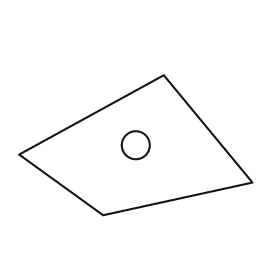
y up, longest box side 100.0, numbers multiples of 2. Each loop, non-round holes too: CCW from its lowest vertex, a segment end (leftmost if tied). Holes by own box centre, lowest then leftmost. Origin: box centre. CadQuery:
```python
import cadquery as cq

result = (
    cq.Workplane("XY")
    .moveTo(-14.0, -30.0)
    .lineTo(50.0, -16.0)
    .lineTo(12.0, 30.0)
    .lineTo(-50.0, -4.0)
    .close()
    .moveTo(0.0, 0.0)
    .circle(6.0)
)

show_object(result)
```